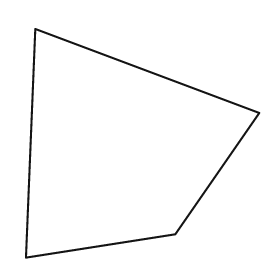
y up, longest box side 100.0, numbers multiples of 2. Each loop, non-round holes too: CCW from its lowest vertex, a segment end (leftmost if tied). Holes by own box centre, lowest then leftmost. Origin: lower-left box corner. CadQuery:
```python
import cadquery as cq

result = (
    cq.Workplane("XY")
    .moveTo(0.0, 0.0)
    .lineTo(64.0, 10.0)
    .lineTo(100.0, 62.0)
    .lineTo(4.0, 98.0)
    .close()
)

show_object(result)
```